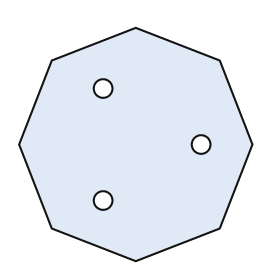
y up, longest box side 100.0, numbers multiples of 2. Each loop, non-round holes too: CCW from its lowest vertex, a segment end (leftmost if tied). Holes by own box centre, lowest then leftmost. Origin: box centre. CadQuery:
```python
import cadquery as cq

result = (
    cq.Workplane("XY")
    .moveTo(0.0, -50.0)
    .lineTo(36.0, -36.0)
    .lineTo(50.0, 0.0)
    .lineTo(36.0, 36.0)
    .lineTo(0.0, 50.0)
    .lineTo(-36.0, 36.0)
    .lineTo(-50.0, 0.0)
    .lineTo(-36.0, -36.0)
    .close()
    .moveTo(-14.0, -24.0)
    .circle(4.0)
    .moveTo(28.0, 0.0)
    .circle(4.0)
    .moveTo(-14.0, 24.0)
    .circle(4.0)
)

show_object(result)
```